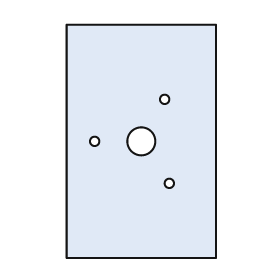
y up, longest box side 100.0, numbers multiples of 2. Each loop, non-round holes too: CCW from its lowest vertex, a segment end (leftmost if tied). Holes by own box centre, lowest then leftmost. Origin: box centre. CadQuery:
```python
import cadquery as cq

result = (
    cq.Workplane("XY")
    .moveTo(-32.0, -50.0)
    .lineTo(32.0, -50.0)
    .lineTo(32.0, 50.0)
    .lineTo(-32.0, 50.0)
    .close()
    .moveTo(12.0, -18.0)
    .circle(2.0)
    .moveTo(-20.0, 0.0)
    .circle(2.0)
    .moveTo(0.0, 0.0)
    .circle(6.0)
    .moveTo(10.0, 18.0)
    .circle(2.0)
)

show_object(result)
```